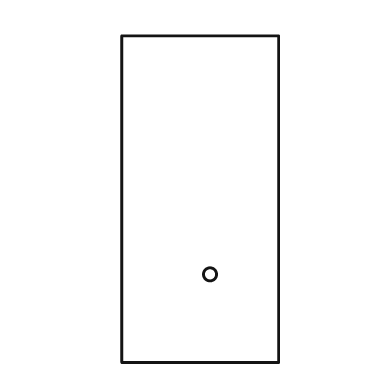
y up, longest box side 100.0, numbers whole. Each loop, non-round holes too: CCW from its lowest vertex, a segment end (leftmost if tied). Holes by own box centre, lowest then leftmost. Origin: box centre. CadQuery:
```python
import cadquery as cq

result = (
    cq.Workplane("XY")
    .moveTo(-24.0, -50.0)
    .lineTo(24.0, -50.0)
    .lineTo(24.0, 50.0)
    .lineTo(-24.0, 50.0)
    .close()
    .moveTo(3.0, -23.0)
    .circle(2.0)
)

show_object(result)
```